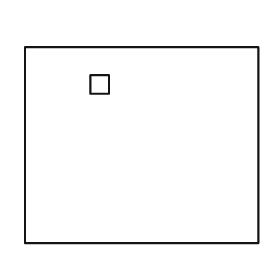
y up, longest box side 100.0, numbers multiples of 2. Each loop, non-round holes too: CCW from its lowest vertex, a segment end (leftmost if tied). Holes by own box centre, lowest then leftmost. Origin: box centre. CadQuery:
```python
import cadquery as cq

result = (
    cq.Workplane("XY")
    .moveTo(-50.0, -42.0)
    .lineTo(50.0, -42.0)
    .lineTo(50.0, 42.0)
    .lineTo(-50.0, 42.0)
    .close()
    .moveTo(-22.0, 22.0)
    .lineTo(-14.0, 22.0)
    .lineTo(-14.0, 30.0)
    .lineTo(-22.0, 30.0)
    .close()
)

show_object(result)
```